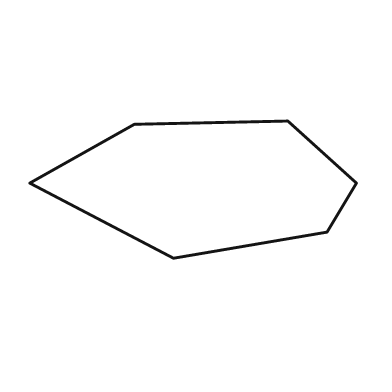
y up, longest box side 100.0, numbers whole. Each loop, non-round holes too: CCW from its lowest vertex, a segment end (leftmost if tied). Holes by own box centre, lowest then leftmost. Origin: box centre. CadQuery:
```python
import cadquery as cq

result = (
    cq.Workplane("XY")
    .moveTo(-6.0, -21.0)
    .lineTo(41.0, -13.0)
    .lineTo(50.0, 2.0)
    .lineTo(29.0, 21.0)
    .lineTo(-18.0, 20.0)
    .lineTo(-50.0, 2.0)
    .close()
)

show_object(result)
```